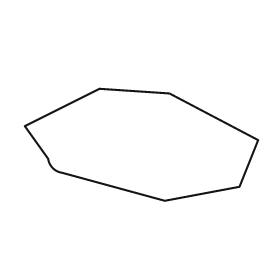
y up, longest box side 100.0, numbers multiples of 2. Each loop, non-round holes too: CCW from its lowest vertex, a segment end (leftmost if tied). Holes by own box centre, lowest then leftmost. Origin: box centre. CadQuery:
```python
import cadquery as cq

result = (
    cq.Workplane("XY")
    .moveTo(10.0, -24.0)
    .lineTo(42.0, -18.0)
    .lineTo(50.0, 2.0)
    .lineTo(12.0, 22.0)
    .lineTo(-18.0, 24.0)
    .lineTo(-50.0, 8.0)
    .lineTo(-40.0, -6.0)
    .threePointArc((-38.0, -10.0), (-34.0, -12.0))
    .close()
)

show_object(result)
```